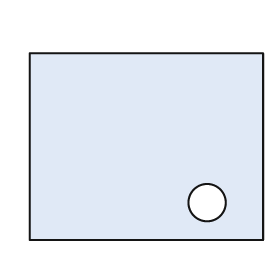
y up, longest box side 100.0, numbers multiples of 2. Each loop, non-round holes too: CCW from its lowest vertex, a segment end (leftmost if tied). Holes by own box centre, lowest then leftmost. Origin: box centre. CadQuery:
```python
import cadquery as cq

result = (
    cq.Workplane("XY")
    .moveTo(-50.0, -40.0)
    .lineTo(50.0, -40.0)
    .lineTo(50.0, 40.0)
    .lineTo(-50.0, 40.0)
    .close()
    .moveTo(26.0, -24.0)
    .circle(8.0)
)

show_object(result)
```